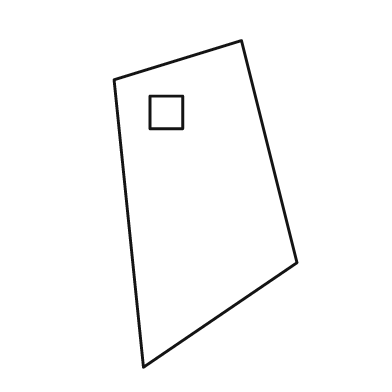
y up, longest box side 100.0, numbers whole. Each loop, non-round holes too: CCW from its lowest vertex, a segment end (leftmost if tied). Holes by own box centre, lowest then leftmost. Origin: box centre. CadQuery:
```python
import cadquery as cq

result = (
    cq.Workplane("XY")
    .moveTo(-19.0, -50.0)
    .lineTo(28.0, -18.0)
    .lineTo(11.0, 50.0)
    .lineTo(-28.0, 38.0)
    .close()
    .moveTo(-17.0, 23.0)
    .lineTo(-7.0, 23.0)
    .lineTo(-7.0, 33.0)
    .lineTo(-17.0, 33.0)
    .close()
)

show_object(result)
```